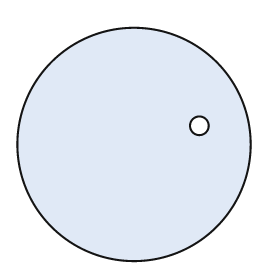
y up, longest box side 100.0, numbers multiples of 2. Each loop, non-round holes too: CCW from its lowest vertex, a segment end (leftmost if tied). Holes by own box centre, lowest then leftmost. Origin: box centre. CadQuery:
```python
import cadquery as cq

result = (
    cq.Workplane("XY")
    .moveTo(0.0, 0.0)
    .circle(50.0)
    .moveTo(28.0, 8.0)
    .circle(4.0)
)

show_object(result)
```